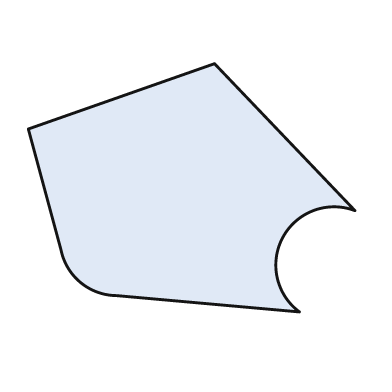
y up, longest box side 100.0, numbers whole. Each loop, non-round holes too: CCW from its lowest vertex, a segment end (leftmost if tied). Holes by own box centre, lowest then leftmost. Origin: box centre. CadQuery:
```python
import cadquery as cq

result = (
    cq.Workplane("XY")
    .moveTo(33.0, -38.0)
    .threePointArc((28.0, -15.0), (50.0, -7.0))
    .lineTo(7.0, 38.0)
    .lineTo(-50.0, 18.0)
    .lineTo(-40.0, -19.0)
    .threePointArc((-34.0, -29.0), (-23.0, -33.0))
    .close()
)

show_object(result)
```